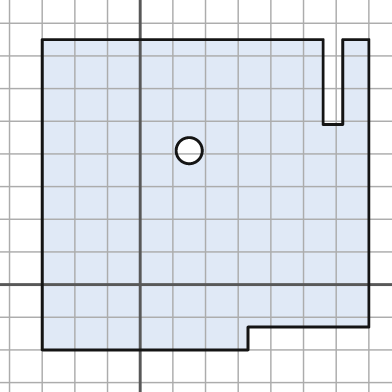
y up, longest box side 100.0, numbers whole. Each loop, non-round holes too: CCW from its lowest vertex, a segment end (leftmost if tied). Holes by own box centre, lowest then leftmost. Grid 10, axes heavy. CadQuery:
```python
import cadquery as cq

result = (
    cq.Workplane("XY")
    .moveTo(-30.0, -20.0)
    .lineTo(33.0, -20.0)
    .lineTo(33.0, -13.0)
    .lineTo(70.0, -13.0)
    .lineTo(70.0, 75.0)
    .lineTo(62.0, 75.0)
    .lineTo(62.0, 49.0)
    .lineTo(56.0, 49.0)
    .lineTo(56.0, 75.0)
    .lineTo(-30.0, 75.0)
    .close()
    .moveTo(15.0, 41.0)
    .circle(4.0)
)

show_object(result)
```